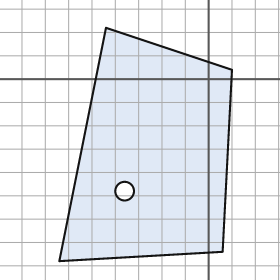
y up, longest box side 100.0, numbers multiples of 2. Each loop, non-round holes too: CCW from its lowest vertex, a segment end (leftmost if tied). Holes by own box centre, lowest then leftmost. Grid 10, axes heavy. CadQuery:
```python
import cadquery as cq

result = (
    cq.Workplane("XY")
    .moveTo(-64.0, -78.0)
    .lineTo(6.0, -74.0)
    .lineTo(10.0, 4.0)
    .lineTo(-44.0, 22.0)
    .close()
    .moveTo(-36.0, -48.0)
    .circle(4.0)
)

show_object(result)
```